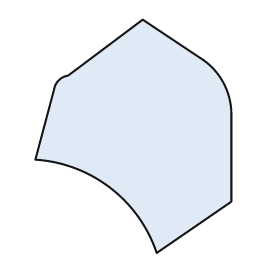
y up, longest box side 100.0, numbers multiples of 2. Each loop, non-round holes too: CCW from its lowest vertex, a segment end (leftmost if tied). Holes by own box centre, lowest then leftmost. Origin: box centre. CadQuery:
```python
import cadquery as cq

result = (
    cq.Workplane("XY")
    .moveTo(10.0, -50.0)
    .lineTo(42.0, -28.0)
    .lineTo(42.0, 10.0)
    .threePointArc((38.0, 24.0), (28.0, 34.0))
    .lineTo(4.0, 50.0)
    .lineTo(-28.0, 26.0)
    .threePointArc((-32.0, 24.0), (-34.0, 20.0))
    .lineTo(-42.0, -10.0)
    .threePointArc((-10.0, -22.0), (10.0, -50.0))
    .close()
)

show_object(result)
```